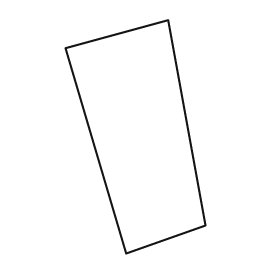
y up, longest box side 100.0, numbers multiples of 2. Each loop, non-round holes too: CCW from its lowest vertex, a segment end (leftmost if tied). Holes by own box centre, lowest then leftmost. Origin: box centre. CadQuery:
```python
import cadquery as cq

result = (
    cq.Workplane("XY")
    .moveTo(-4.0, -50.0)
    .lineTo(30.0, -38.0)
    .lineTo(14.0, 50.0)
    .lineTo(-30.0, 38.0)
    .close()
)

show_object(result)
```